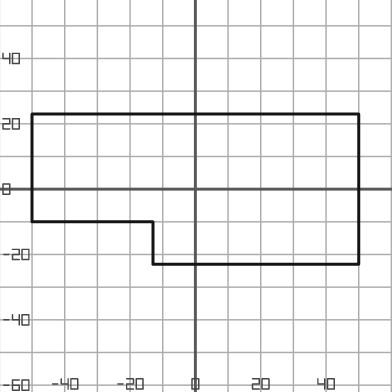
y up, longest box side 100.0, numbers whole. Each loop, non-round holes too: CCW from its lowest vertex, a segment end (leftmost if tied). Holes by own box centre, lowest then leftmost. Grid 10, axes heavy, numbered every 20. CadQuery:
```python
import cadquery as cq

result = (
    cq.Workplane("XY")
    .moveTo(-13.0, -23.0)
    .lineTo(50.0, -23.0)
    .lineTo(50.0, 23.0)
    .lineTo(-50.0, 23.0)
    .lineTo(-50.0, -10.0)
    .lineTo(-13.0, -10.0)
    .close()
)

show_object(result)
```